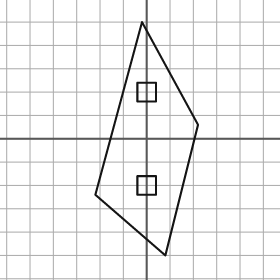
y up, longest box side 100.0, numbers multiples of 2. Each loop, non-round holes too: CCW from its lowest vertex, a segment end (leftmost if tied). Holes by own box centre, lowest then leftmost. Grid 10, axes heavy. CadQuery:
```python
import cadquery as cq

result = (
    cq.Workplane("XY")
    .moveTo(8.0, -50.0)
    .lineTo(22.0, 6.0)
    .lineTo(-2.0, 50.0)
    .lineTo(-22.0, -24.0)
    .close()
    .moveTo(-4.0, -24.0)
    .lineTo(4.0, -24.0)
    .lineTo(4.0, -16.0)
    .lineTo(-4.0, -16.0)
    .close()
    .moveTo(-4.0, 16.0)
    .lineTo(4.0, 16.0)
    .lineTo(4.0, 24.0)
    .lineTo(-4.0, 24.0)
    .close()
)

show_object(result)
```